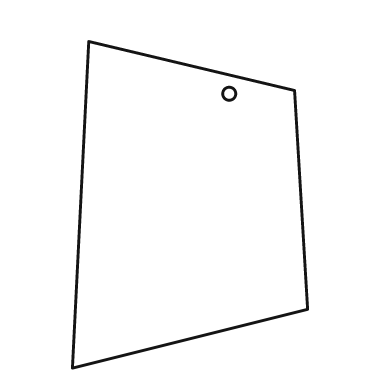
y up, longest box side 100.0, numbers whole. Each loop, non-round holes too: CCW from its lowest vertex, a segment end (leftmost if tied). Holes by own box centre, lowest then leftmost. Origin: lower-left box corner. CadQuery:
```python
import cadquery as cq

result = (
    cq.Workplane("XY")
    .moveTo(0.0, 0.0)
    .lineTo(72.0, 18.0)
    .lineTo(68.0, 85.0)
    .lineTo(5.0, 100.0)
    .close()
    .moveTo(48.0, 84.0)
    .circle(2.0)
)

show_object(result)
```